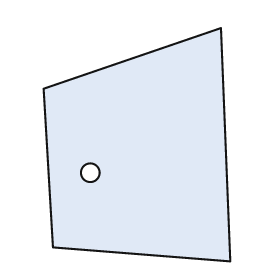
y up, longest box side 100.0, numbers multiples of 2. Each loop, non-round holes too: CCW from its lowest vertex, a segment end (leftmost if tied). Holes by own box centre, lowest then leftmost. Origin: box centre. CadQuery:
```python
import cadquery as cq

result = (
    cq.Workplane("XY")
    .moveTo(40.0, -50.0)
    .lineTo(36.0, 50.0)
    .lineTo(-40.0, 24.0)
    .lineTo(-36.0, -44.0)
    .close()
    .moveTo(-20.0, -12.0)
    .circle(4.0)
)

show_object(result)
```